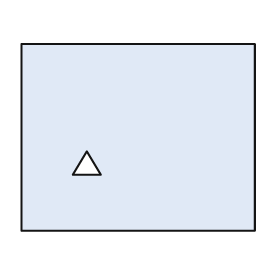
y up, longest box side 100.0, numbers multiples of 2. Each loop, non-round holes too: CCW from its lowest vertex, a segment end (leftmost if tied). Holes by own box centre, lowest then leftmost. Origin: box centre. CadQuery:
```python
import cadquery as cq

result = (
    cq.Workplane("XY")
    .moveTo(-50.0, -40.0)
    .lineTo(50.0, -40.0)
    .lineTo(50.0, 40.0)
    .lineTo(-50.0, 40.0)
    .close()
    .moveTo(-28.0, -16.0)
    .lineTo(-16.0, -16.0)
    .lineTo(-22.0, -6.0)
    .close()
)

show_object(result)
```